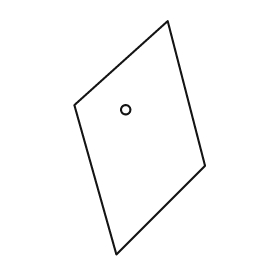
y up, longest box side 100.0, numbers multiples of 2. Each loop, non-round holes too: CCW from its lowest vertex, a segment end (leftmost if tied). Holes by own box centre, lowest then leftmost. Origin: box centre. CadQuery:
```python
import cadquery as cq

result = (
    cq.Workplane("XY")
    .moveTo(-10.0, -50.0)
    .lineTo(28.0, -12.0)
    .lineTo(12.0, 50.0)
    .lineTo(-28.0, 14.0)
    .close()
    .moveTo(-6.0, 12.0)
    .circle(2.0)
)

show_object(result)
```